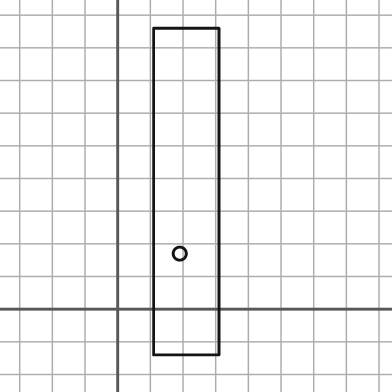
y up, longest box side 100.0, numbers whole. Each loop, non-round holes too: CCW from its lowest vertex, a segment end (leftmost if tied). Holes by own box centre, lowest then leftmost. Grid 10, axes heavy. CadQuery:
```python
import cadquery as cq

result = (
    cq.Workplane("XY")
    .moveTo(11.0, -14.0)
    .lineTo(31.0, -14.0)
    .lineTo(31.0, 86.0)
    .lineTo(11.0, 86.0)
    .close()
    .moveTo(19.0, 17.0)
    .circle(2.0)
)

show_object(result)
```